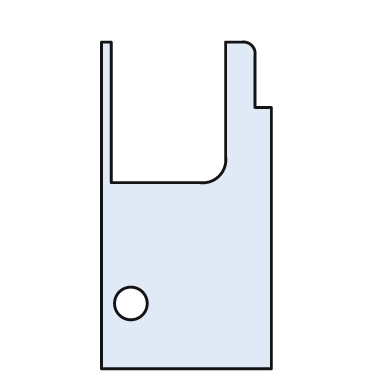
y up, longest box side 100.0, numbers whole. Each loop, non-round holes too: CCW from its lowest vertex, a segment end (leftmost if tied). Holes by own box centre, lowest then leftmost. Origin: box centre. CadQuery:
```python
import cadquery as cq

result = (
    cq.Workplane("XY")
    .moveTo(-26.0, -50.0)
    .lineTo(26.0, -50.0)
    .lineTo(26.0, 30.0)
    .lineTo(21.0, 30.0)
    .lineTo(21.0, 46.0)
    .threePointArc((20.0, 49.0), (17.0, 50.0))
    .lineTo(12.0, 50.0)
    .lineTo(12.0, 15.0)
    .threePointArc((10.0, 9.0), (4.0, 7.0))
    .lineTo(-23.0, 7.0)
    .lineTo(-23.0, 50.0)
    .lineTo(-26.0, 50.0)
    .close()
    .moveTo(-17.0, -30.0)
    .circle(5.0)
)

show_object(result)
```